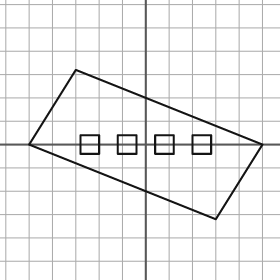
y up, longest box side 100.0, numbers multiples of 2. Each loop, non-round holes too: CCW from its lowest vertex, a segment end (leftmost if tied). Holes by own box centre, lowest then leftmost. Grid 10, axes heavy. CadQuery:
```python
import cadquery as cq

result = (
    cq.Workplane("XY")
    .moveTo(30.0, -32.0)
    .lineTo(50.0, 0.0)
    .lineTo(-30.0, 32.0)
    .lineTo(-50.0, 0.0)
    .close()
    .moveTo(-28.0, -4.0)
    .lineTo(-20.0, -4.0)
    .lineTo(-20.0, 4.0)
    .lineTo(-28.0, 4.0)
    .close()
    .moveTo(-12.0, -4.0)
    .lineTo(-4.0, -4.0)
    .lineTo(-4.0, 4.0)
    .lineTo(-12.0, 4.0)
    .close()
    .moveTo(4.0, -4.0)
    .lineTo(12.0, -4.0)
    .lineTo(12.0, 4.0)
    .lineTo(4.0, 4.0)
    .close()
    .moveTo(20.0, -4.0)
    .lineTo(28.0, -4.0)
    .lineTo(28.0, 4.0)
    .lineTo(20.0, 4.0)
    .close()
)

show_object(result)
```